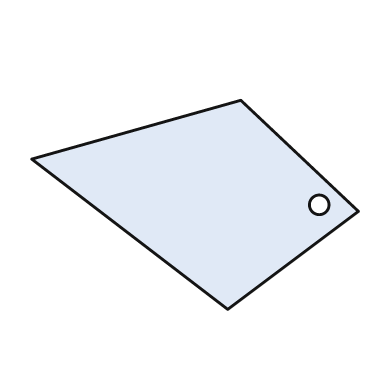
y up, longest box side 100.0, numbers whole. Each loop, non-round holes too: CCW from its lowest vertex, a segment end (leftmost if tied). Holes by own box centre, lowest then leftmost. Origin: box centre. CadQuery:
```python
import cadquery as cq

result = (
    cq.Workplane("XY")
    .moveTo(10.0, -32.0)
    .lineTo(50.0, -2.0)
    .lineTo(14.0, 32.0)
    .lineTo(-50.0, 14.0)
    .close()
    .moveTo(38.0, 0.0)
    .circle(3.0)
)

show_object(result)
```